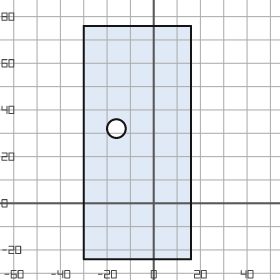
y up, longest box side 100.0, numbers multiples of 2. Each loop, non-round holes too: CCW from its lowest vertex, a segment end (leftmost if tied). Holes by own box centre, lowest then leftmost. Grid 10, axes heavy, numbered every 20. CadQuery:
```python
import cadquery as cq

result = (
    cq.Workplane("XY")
    .moveTo(-30.0, -24.0)
    .lineTo(16.0, -24.0)
    .lineTo(16.0, 76.0)
    .lineTo(-30.0, 76.0)
    .close()
    .moveTo(-16.0, 32.0)
    .circle(4.0)
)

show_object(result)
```